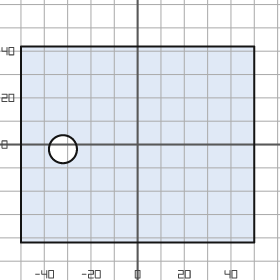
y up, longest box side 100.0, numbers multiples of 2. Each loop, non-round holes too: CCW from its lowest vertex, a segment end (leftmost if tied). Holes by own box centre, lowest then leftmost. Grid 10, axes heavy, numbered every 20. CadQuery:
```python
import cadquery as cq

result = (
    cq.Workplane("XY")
    .moveTo(-50.0, -42.0)
    .lineTo(50.0, -42.0)
    .lineTo(50.0, 42.0)
    .lineTo(-50.0, 42.0)
    .close()
    .moveTo(-32.0, -2.0)
    .circle(6.0)
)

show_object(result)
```